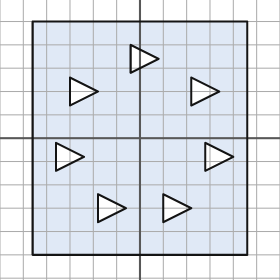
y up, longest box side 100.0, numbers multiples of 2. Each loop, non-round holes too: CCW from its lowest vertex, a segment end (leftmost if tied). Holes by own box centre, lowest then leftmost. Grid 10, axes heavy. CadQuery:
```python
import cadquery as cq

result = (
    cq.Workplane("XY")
    .moveTo(-46.0, -50.0)
    .lineTo(46.0, -50.0)
    .lineTo(46.0, 50.0)
    .lineTo(-46.0, 50.0)
    .close()
    .moveTo(-18.0, -36.0)
    .lineTo(-6.0, -30.0)
    .lineTo(-18.0, -24.0)
    .close()
    .moveTo(10.0, -36.0)
    .lineTo(22.0, -30.0)
    .lineTo(10.0, -24.0)
    .close()
    .moveTo(-36.0, -14.0)
    .lineTo(-24.0, -8.0)
    .lineTo(-36.0, -2.0)
    .close()
    .moveTo(28.0, -14.0)
    .lineTo(40.0, -8.0)
    .lineTo(28.0, -2.0)
    .close()
    .moveTo(-30.0, 14.0)
    .lineTo(-18.0, 20.0)
    .lineTo(-30.0, 26.0)
    .close()
    .moveTo(22.0, 14.0)
    .lineTo(34.0, 20.0)
    .lineTo(22.0, 26.0)
    .close()
    .moveTo(-4.0, 28.0)
    .lineTo(8.0, 34.0)
    .lineTo(-4.0, 40.0)
    .close()
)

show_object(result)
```